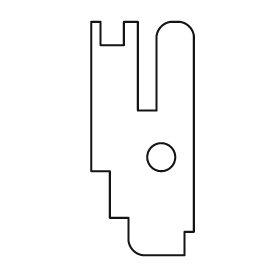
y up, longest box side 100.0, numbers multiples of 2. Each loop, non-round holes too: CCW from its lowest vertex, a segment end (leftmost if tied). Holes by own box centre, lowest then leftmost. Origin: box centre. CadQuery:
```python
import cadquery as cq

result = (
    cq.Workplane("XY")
    .moveTo(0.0, -50.0)
    .lineTo(18.0, -50.0)
    .lineTo(18.0, -40.0)
    .lineTo(22.0, -40.0)
    .lineTo(22.0, 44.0)
    .threePointArc((20.0, 48.0), (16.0, 50.0))
    .lineTo(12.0, 50.0)
    .threePointArc((8.0, 48.0), (6.0, 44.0))
    .lineTo(6.0, 12.0)
    .lineTo(-2.0, 12.0)
    .lineTo(-2.0, 50.0)
    .lineTo(-8.0, 50.0)
    .lineTo(-8.0, 40.0)
    .lineTo(-18.0, 40.0)
    .lineTo(-18.0, 50.0)
    .lineTo(-22.0, 50.0)
    .lineTo(-22.0, -14.0)
    .lineTo(-14.0, -14.0)
    .lineTo(-14.0, -34.0)
    .lineTo(-6.0, -34.0)
    .lineTo(-6.0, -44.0)
    .threePointArc((-4.0, -48.0), (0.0, -50.0))
    .close()
    .moveTo(8.0, -8.0)
    .circle(6.0)
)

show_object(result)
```